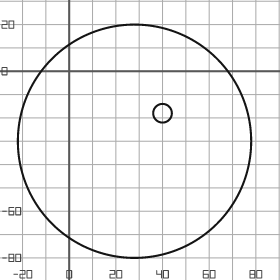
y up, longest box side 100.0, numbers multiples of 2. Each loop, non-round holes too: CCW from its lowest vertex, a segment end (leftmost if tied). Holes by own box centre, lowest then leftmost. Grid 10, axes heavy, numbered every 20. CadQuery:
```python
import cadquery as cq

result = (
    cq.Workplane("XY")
    .moveTo(28.0, -30.0)
    .circle(50.0)
    .moveTo(40.0, -18.0)
    .circle(4.0)
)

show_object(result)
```